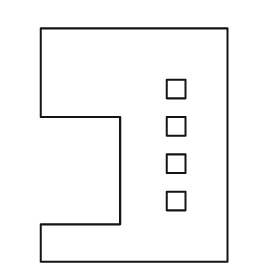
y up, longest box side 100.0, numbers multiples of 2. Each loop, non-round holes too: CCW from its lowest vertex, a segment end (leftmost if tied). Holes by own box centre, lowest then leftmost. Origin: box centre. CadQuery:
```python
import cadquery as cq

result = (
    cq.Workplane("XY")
    .moveTo(-40.0, -50.0)
    .lineTo(40.0, -50.0)
    .lineTo(40.0, 50.0)
    .lineTo(-40.0, 50.0)
    .lineTo(-40.0, 12.0)
    .lineTo(-6.0, 12.0)
    .lineTo(-6.0, -34.0)
    .lineTo(-40.0, -34.0)
    .close()
    .moveTo(14.0, -28.0)
    .lineTo(22.0, -28.0)
    .lineTo(22.0, -20.0)
    .lineTo(14.0, -20.0)
    .close()
    .moveTo(14.0, -12.0)
    .lineTo(22.0, -12.0)
    .lineTo(22.0, -4.0)
    .lineTo(14.0, -4.0)
    .close()
    .moveTo(14.0, 4.0)
    .lineTo(22.0, 4.0)
    .lineTo(22.0, 12.0)
    .lineTo(14.0, 12.0)
    .close()
    .moveTo(14.0, 20.0)
    .lineTo(22.0, 20.0)
    .lineTo(22.0, 28.0)
    .lineTo(14.0, 28.0)
    .close()
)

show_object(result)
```